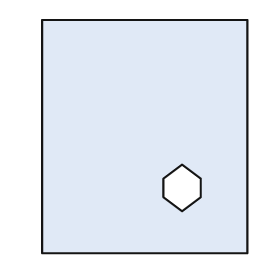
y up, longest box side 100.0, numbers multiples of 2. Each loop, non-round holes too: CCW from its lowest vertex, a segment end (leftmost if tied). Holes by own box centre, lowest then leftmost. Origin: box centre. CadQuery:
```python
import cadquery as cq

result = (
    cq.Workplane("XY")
    .moveTo(-44.0, -50.0)
    .lineTo(44.0, -50.0)
    .lineTo(44.0, 50.0)
    .lineTo(-44.0, 50.0)
    .close()
    .moveTo(16.0, -32.0)
    .lineTo(24.0, -26.0)
    .lineTo(24.0, -18.0)
    .lineTo(16.0, -12.0)
    .lineTo(8.0, -18.0)
    .lineTo(8.0, -26.0)
    .close()
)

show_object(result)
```